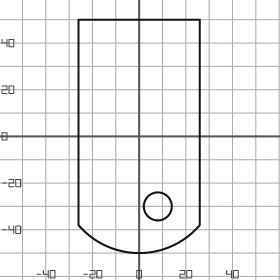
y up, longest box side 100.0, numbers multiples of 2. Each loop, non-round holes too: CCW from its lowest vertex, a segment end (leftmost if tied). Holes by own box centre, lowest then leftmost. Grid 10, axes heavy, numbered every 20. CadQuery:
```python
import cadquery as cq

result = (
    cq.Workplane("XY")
    .moveTo(-26.0, -38.0)
    .threePointArc((0.0, -50.0), (26.0, -38.0))
    .lineTo(26.0, 50.0)
    .lineTo(-26.0, 50.0)
    .close()
    .moveTo(8.0, -30.0)
    .circle(6.0)
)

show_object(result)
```